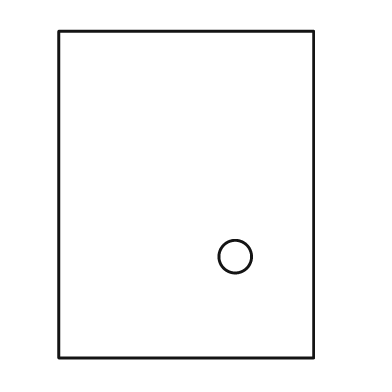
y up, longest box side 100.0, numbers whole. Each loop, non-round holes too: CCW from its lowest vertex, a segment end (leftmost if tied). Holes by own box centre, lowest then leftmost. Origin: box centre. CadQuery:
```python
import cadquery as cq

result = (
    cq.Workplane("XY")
    .moveTo(-39.0, -50.0)
    .lineTo(39.0, -50.0)
    .lineTo(39.0, 50.0)
    .lineTo(-39.0, 50.0)
    .close()
    .moveTo(15.0, -19.0)
    .circle(5.0)
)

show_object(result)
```